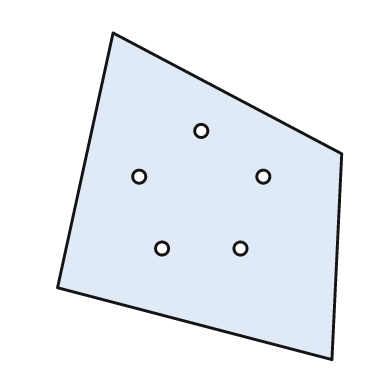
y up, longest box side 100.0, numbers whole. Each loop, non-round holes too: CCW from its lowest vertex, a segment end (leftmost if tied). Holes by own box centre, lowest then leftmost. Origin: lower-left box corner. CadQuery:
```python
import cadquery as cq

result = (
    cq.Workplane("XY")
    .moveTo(84.0, 0.0)
    .lineTo(87.0, 63.0)
    .lineTo(17.0, 100.0)
    .lineTo(0.0, 22.0)
    .close()
    .moveTo(32.0, 34.0)
    .circle(2.0)
    .moveTo(56.0, 34.0)
    .circle(2.0)
    .moveTo(25.0, 56.0)
    .circle(2.0)
    .moveTo(63.0, 56.0)
    .circle(2.0)
    .moveTo(44.0, 70.0)
    .circle(2.0)
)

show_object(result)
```